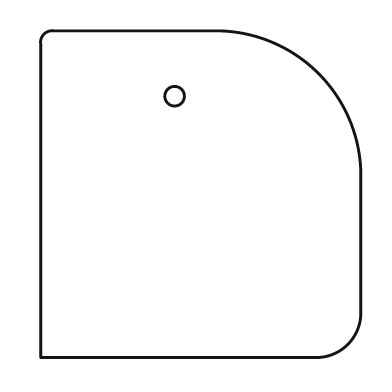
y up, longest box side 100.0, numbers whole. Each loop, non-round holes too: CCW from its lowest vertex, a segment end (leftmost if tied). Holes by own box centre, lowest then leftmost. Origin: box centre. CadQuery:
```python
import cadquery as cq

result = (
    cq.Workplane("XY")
    .moveTo(-49.0, -50.0)
    .lineTo(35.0, -50.0)
    .threePointArc((45.0, -46.0), (49.0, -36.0))
    .lineTo(49.0, 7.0)
    .threePointArc((36.0, 37.0), (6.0, 50.0))
    .lineTo(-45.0, 50.0)
    .threePointArc((-48.0, 49.0), (-49.0, 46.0))
    .close()
    .moveTo(-8.0, 30.0)
    .circle(3.0)
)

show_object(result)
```